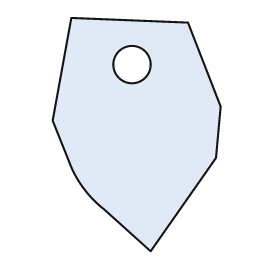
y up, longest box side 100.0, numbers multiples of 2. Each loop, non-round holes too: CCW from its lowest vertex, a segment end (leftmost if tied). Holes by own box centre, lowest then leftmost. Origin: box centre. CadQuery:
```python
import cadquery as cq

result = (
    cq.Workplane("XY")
    .moveTo(6.0, -50.0)
    .lineTo(34.0, -10.0)
    .lineTo(36.0, 12.0)
    .lineTo(22.0, 48.0)
    .lineTo(-28.0, 50.0)
    .lineTo(-36.0, 6.0)
    .lineTo(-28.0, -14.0)
    .threePointArc((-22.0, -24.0), (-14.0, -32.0))
    .close()
    .moveTo(-2.0, 30.0)
    .circle(8.0)
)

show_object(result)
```